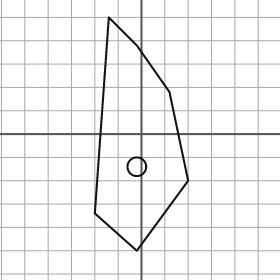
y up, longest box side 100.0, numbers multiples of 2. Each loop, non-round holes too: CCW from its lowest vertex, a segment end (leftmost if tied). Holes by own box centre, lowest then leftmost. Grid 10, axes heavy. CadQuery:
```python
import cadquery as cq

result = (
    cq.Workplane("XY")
    .moveTo(-2.0, -50.0)
    .lineTo(20.0, -20.0)
    .lineTo(12.0, 18.0)
    .lineTo(-2.0, 38.0)
    .lineTo(-14.0, 50.0)
    .lineTo(-20.0, -34.0)
    .close()
    .moveTo(-2.0, -14.0)
    .circle(4.0)
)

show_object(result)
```